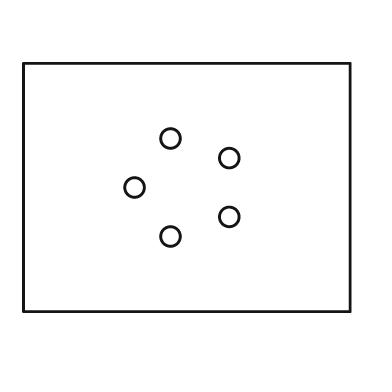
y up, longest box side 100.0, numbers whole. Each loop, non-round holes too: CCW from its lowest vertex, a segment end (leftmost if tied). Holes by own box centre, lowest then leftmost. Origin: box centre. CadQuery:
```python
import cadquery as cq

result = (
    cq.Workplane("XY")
    .moveTo(-50.0, -38.0)
    .lineTo(50.0, -38.0)
    .lineTo(50.0, 38.0)
    .lineTo(-50.0, 38.0)
    .close()
    .moveTo(-5.0, -15.0)
    .circle(3.0)
    .moveTo(13.0, -9.0)
    .circle(3.0)
    .moveTo(-16.0, 0.0)
    .circle(3.0)
    .moveTo(13.0, 9.0)
    .circle(3.0)
    .moveTo(-5.0, 15.0)
    .circle(3.0)
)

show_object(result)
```